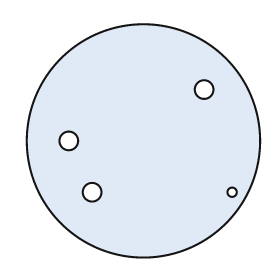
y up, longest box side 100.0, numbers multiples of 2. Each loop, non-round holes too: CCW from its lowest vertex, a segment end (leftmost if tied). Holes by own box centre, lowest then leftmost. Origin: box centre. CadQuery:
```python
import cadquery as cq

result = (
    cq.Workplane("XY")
    .moveTo(0.0, 0.0)
    .circle(50.0)
    .moveTo(-22.0, -22.0)
    .circle(4.0)
    .moveTo(38.0, -22.0)
    .circle(2.0)
    .moveTo(-32.0, 0.0)
    .circle(4.0)
    .moveTo(26.0, 22.0)
    .circle(4.0)
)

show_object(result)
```